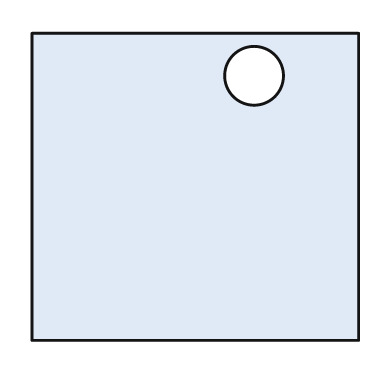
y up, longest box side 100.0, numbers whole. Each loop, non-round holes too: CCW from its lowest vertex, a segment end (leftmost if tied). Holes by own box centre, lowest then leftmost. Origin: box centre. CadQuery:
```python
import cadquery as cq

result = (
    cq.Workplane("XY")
    .moveTo(-50.0, -47.0)
    .lineTo(50.0, -47.0)
    .lineTo(50.0, 47.0)
    .lineTo(-50.0, 47.0)
    .close()
    .moveTo(18.0, 34.0)
    .circle(9.0)
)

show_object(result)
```